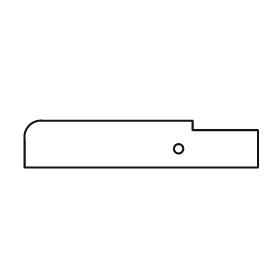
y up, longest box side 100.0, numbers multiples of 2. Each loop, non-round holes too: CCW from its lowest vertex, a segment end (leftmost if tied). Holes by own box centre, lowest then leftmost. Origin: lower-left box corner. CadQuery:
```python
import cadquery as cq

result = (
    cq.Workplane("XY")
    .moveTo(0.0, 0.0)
    .lineTo(100.0, 0.0)
    .lineTo(100.0, 16.0)
    .lineTo(72.0, 16.0)
    .lineTo(72.0, 20.0)
    .lineTo(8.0, 20.0)
    .threePointArc((2.0, 18.0), (0.0, 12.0))
    .close()
    .moveTo(66.0, 8.0)
    .circle(2.0)
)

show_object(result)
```